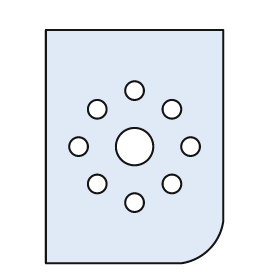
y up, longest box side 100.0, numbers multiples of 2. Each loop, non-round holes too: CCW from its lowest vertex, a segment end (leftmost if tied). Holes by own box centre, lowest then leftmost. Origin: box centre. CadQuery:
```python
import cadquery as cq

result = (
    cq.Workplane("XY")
    .moveTo(-38.0, -50.0)
    .lineTo(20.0, -50.0)
    .threePointArc((32.0, -44.0), (38.0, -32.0))
    .lineTo(38.0, 50.0)
    .lineTo(-38.0, 50.0)
    .close()
    .moveTo(0.0, -24.0)
    .circle(4.0)
    .moveTo(-16.0, -16.0)
    .circle(4.0)
    .moveTo(16.0, -16.0)
    .circle(4.0)
    .moveTo(-24.0, 0.0)
    .circle(4.0)
    .moveTo(0.0, 0.0)
    .circle(8.0)
    .moveTo(24.0, 0.0)
    .circle(4.0)
    .moveTo(-16.0, 16.0)
    .circle(4.0)
    .moveTo(16.0, 16.0)
    .circle(4.0)
    .moveTo(0.0, 24.0)
    .circle(4.0)
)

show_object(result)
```